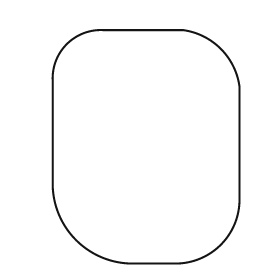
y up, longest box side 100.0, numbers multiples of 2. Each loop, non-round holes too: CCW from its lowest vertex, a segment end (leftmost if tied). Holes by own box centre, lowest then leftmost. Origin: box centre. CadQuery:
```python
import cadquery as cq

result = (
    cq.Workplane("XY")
    .moveTo(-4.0, -50.0)
    .lineTo(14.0, -50.0)
    .threePointArc((32.0, -42.0), (40.0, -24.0))
    .lineTo(40.0, 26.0)
    .threePointArc((32.0, 42.0), (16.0, 50.0))
    .lineTo(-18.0, 50.0)
    .threePointArc((-34.0, 44.0), (-40.0, 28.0))
    .lineTo(-40.0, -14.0)
    .threePointArc((-30.0, -40.0), (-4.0, -50.0))
    .close()
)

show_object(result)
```